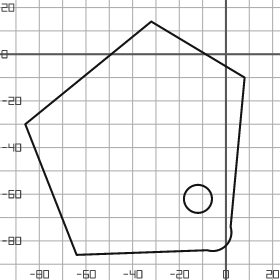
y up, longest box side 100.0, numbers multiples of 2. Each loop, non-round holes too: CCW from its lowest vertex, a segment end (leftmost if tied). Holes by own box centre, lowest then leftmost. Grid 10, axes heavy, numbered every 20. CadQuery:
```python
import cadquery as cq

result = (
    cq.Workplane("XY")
    .moveTo(-64.0, -86.0)
    .lineTo(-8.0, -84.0)
    .threePointArc((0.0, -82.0), (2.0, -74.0))
    .lineTo(8.0, -10.0)
    .lineTo(-32.0, 14.0)
    .lineTo(-86.0, -30.0)
    .close()
    .moveTo(-12.0, -62.0)
    .circle(6.0)
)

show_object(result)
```